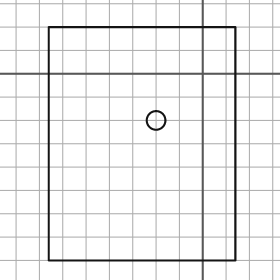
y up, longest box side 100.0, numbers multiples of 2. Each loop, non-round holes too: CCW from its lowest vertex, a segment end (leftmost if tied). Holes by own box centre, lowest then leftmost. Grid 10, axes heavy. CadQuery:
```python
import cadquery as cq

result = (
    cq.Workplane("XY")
    .moveTo(-66.0, -80.0)
    .lineTo(14.0, -80.0)
    .lineTo(14.0, 20.0)
    .lineTo(-66.0, 20.0)
    .close()
    .moveTo(-20.0, -20.0)
    .circle(4.0)
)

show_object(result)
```